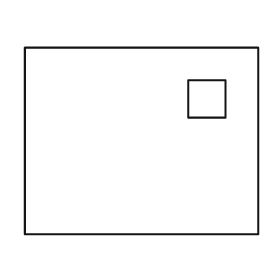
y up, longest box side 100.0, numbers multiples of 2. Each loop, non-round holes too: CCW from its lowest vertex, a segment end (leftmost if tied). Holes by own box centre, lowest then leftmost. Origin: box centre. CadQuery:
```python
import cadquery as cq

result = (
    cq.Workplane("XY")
    .moveTo(-50.0, -40.0)
    .lineTo(50.0, -40.0)
    .lineTo(50.0, 40.0)
    .lineTo(-50.0, 40.0)
    .close()
    .moveTo(20.0, 10.0)
    .lineTo(36.0, 10.0)
    .lineTo(36.0, 26.0)
    .lineTo(20.0, 26.0)
    .close()
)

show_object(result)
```